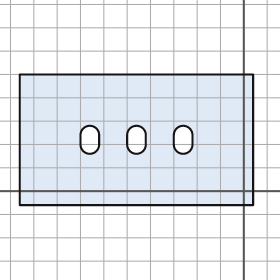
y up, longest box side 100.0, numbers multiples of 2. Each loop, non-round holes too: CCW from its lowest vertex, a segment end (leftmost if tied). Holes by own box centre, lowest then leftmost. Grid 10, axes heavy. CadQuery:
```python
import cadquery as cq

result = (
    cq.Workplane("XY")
    .moveTo(-96.0, -6.0)
    .lineTo(4.0, -6.0)
    .lineTo(4.0, 50.0)
    .lineTo(-96.0, 50.0)
    .close()
    .moveTo(-70.0, 20.0)
    .threePointArc((-66.0, 16.0), (-62.0, 20.0))
    .lineTo(-62.0, 24.0)
    .threePointArc((-66.0, 28.0), (-70.0, 24.0))
    .close()
    .moveTo(-50.0, 20.0)
    .threePointArc((-46.0, 16.0), (-42.0, 20.0))
    .lineTo(-42.0, 24.0)
    .threePointArc((-46.0, 28.0), (-50.0, 24.0))
    .close()
    .moveTo(-30.0, 20.0)
    .threePointArc((-26.0, 16.0), (-22.0, 20.0))
    .lineTo(-22.0, 24.0)
    .threePointArc((-26.0, 28.0), (-30.0, 24.0))
    .close()
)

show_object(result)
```